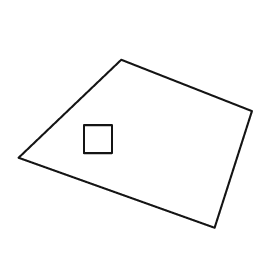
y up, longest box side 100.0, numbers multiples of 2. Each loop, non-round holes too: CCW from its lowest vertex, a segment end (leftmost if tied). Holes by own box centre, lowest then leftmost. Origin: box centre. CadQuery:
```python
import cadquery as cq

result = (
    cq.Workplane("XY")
    .moveTo(34.0, -36.0)
    .lineTo(50.0, 14.0)
    .lineTo(-6.0, 36.0)
    .lineTo(-50.0, -6.0)
    .close()
    .moveTo(-22.0, -4.0)
    .lineTo(-10.0, -4.0)
    .lineTo(-10.0, 8.0)
    .lineTo(-22.0, 8.0)
    .close()
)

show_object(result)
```